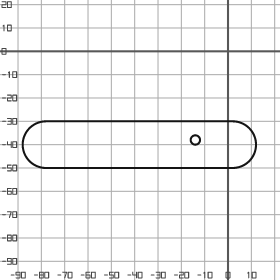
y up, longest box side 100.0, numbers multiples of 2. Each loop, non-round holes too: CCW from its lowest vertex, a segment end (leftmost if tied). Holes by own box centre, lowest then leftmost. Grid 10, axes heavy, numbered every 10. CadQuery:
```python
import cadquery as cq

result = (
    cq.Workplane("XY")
    .moveTo(-78.0, -50.0)
    .lineTo(2.0, -50.0)
    .threePointArc((12.0, -40.0), (2.0, -30.0))
    .lineTo(-78.0, -30.0)
    .threePointArc((-88.0, -40.0), (-78.0, -50.0))
    .close()
    .moveTo(-14.0, -38.0)
    .circle(2.0)
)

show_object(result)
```